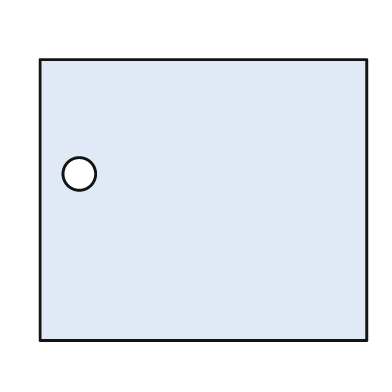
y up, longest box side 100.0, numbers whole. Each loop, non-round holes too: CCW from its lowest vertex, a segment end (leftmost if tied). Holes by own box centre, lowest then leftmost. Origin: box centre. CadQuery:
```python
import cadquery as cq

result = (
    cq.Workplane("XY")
    .moveTo(-50.0, -43.0)
    .lineTo(50.0, -43.0)
    .lineTo(50.0, 43.0)
    .lineTo(-50.0, 43.0)
    .close()
    .moveTo(-38.0, 8.0)
    .circle(5.0)
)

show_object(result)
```